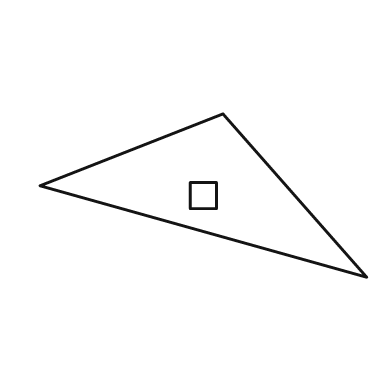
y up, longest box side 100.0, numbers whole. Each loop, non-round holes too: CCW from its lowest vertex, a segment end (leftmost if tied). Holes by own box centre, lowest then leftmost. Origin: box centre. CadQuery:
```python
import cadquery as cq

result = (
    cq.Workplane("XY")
    .moveTo(50.0, -25.0)
    .lineTo(6.0, 25.0)
    .lineTo(-50.0, 3.0)
    .close()
    .moveTo(-4.0, -4.0)
    .lineTo(4.0, -4.0)
    .lineTo(4.0, 4.0)
    .lineTo(-4.0, 4.0)
    .close()
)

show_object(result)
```